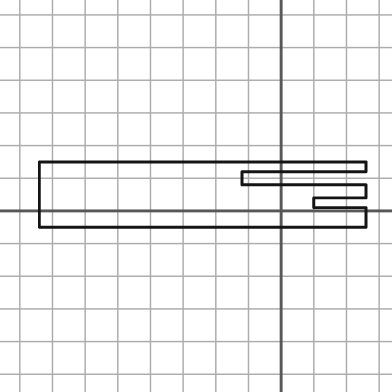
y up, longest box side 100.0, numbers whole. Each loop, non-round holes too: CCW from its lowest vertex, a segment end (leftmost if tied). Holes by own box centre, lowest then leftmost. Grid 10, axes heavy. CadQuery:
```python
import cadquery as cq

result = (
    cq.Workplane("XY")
    .moveTo(-74.0, -5.0)
    .lineTo(26.0, -5.0)
    .lineTo(26.0, 1.0)
    .lineTo(10.0, 1.0)
    .lineTo(10.0, 4.0)
    .lineTo(26.0, 4.0)
    .lineTo(26.0, 8.0)
    .lineTo(-12.0, 8.0)
    .lineTo(-12.0, 12.0)
    .lineTo(26.0, 12.0)
    .lineTo(26.0, 15.0)
    .lineTo(-74.0, 15.0)
    .close()
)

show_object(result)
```